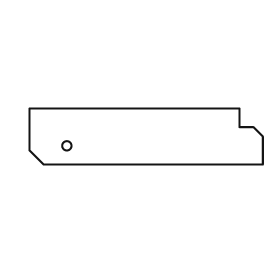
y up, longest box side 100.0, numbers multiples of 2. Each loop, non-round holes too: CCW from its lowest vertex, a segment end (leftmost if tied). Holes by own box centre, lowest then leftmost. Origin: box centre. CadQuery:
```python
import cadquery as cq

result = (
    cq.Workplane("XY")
    .moveTo(-44.0, -12.0)
    .lineTo(50.0, -12.0)
    .lineTo(50.0, 0.0)
    .lineTo(46.0, 4.0)
    .lineTo(40.0, 4.0)
    .lineTo(40.0, 12.0)
    .lineTo(-50.0, 12.0)
    .lineTo(-50.0, -6.0)
    .close()
    .moveTo(-34.0, -4.0)
    .circle(2.0)
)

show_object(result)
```